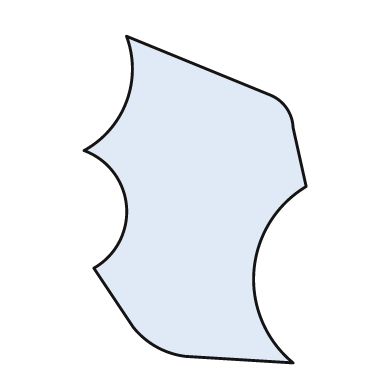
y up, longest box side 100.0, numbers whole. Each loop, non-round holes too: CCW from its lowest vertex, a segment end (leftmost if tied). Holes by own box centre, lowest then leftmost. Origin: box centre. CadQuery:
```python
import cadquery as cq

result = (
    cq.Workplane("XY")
    .moveTo(30.0, -50.0)
    .threePointArc((18.0, -22.0), (34.0, 4.0))
    .lineTo(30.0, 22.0)
    .threePointArc((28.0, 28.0), (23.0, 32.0))
    .lineTo(-21.0, 50.0)
    .threePointArc((-21.0, 30.0), (-34.0, 15.0))
    .threePointArc((-21.0, -2.0), (-31.0, -21.0))
    .lineTo(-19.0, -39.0)
    .threePointArc((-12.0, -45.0), (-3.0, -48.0))
    .close()
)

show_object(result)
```